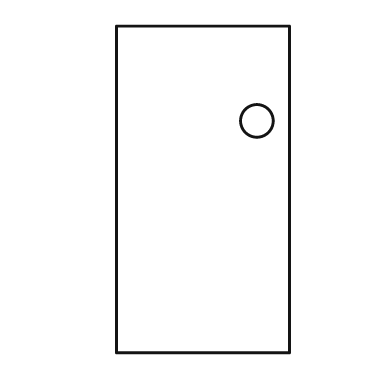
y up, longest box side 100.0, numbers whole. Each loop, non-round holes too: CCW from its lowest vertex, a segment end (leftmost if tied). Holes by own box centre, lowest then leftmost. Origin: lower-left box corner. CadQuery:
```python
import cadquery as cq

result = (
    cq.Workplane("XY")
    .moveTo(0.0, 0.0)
    .lineTo(53.0, 0.0)
    .lineTo(53.0, 100.0)
    .lineTo(0.0, 100.0)
    .close()
    .moveTo(43.0, 71.0)
    .circle(5.0)
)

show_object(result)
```